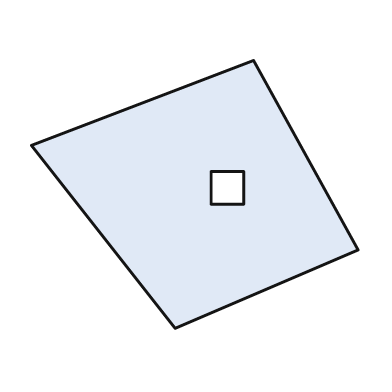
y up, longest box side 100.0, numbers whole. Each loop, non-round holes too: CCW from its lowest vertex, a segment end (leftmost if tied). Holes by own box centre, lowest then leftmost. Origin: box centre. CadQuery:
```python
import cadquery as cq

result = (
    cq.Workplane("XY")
    .moveTo(-6.0, -41.0)
    .lineTo(50.0, -17.0)
    .lineTo(18.0, 41.0)
    .lineTo(-50.0, 15.0)
    .close()
    .moveTo(5.0, -3.0)
    .lineTo(15.0, -3.0)
    .lineTo(15.0, 7.0)
    .lineTo(5.0, 7.0)
    .close()
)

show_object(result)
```